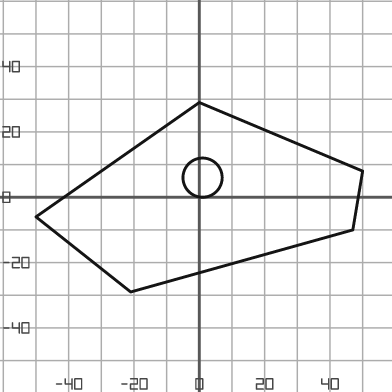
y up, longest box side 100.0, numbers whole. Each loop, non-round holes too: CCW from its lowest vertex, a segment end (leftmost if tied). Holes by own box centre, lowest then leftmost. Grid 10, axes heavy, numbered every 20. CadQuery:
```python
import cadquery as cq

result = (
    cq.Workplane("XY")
    .moveTo(-21.0, -29.0)
    .lineTo(47.0, -10.0)
    .lineTo(50.0, 8.0)
    .lineTo(0.0, 29.0)
    .lineTo(-50.0, -6.0)
    .close()
    .moveTo(1.0, 6.0)
    .circle(6.0)
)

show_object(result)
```